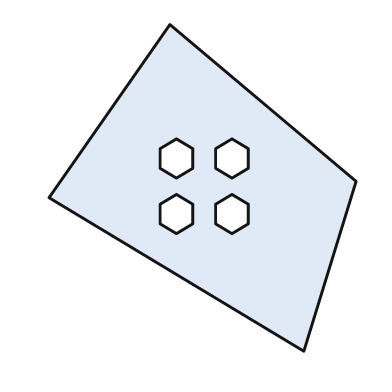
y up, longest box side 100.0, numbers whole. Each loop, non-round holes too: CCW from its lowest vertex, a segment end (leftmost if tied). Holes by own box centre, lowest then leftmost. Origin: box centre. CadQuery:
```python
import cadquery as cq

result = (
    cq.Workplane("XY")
    .moveTo(31.0, -50.0)
    .lineTo(47.0, 2.0)
    .lineTo(-10.0, 50.0)
    .lineTo(-47.0, -3.0)
    .close()
    .moveTo(-8.0, -14.0)
    .lineTo(-3.0, -11.0)
    .lineTo(-3.0, -5.0)
    .lineTo(-8.0, -2.0)
    .lineTo(-13.0, -5.0)
    .lineTo(-13.0, -11.0)
    .close()
    .moveTo(9.0, -14.0)
    .lineTo(14.0, -11.0)
    .lineTo(14.0, -5.0)
    .lineTo(9.0, -2.0)
    .lineTo(4.0, -5.0)
    .lineTo(4.0, -11.0)
    .close()
    .moveTo(-8.0, 3.0)
    .lineTo(-3.0, 6.0)
    .lineTo(-3.0, 12.0)
    .lineTo(-8.0, 15.0)
    .lineTo(-13.0, 12.0)
    .lineTo(-13.0, 6.0)
    .close()
    .moveTo(9.0, 3.0)
    .lineTo(14.0, 6.0)
    .lineTo(14.0, 12.0)
    .lineTo(9.0, 15.0)
    .lineTo(4.0, 12.0)
    .lineTo(4.0, 6.0)
    .close()
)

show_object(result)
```